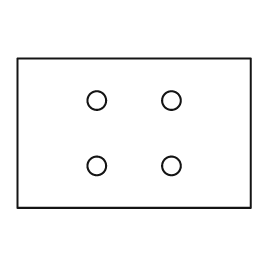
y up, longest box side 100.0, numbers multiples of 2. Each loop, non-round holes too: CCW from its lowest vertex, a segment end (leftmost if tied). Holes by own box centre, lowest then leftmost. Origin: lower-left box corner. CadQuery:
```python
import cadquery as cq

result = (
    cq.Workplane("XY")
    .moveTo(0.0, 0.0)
    .lineTo(100.0, 0.0)
    .lineTo(100.0, 64.0)
    .lineTo(0.0, 64.0)
    .close()
    .moveTo(34.0, 18.0)
    .circle(4.0)
    .moveTo(66.0, 18.0)
    .circle(4.0)
    .moveTo(34.0, 46.0)
    .circle(4.0)
    .moveTo(66.0, 46.0)
    .circle(4.0)
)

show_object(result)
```